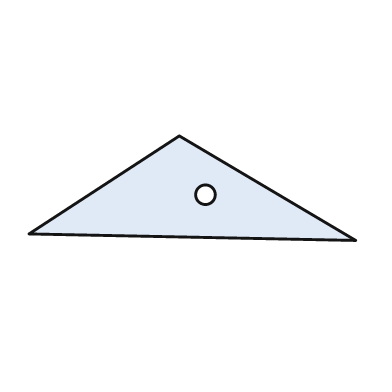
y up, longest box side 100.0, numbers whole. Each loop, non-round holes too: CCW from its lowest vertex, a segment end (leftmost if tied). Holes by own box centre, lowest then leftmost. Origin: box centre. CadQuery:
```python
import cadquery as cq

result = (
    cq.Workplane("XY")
    .moveTo(50.0, -16.0)
    .lineTo(-4.0, 16.0)
    .lineTo(-50.0, -14.0)
    .close()
    .moveTo(4.0, -2.0)
    .circle(3.0)
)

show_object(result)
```